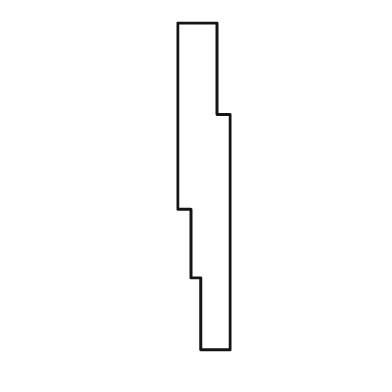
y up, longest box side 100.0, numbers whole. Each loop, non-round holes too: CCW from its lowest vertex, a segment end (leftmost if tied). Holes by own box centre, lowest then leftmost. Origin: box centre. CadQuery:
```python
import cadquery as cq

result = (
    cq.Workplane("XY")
    .moveTo(-1.0, -50.0)
    .lineTo(8.0, -50.0)
    .lineTo(8.0, 22.0)
    .lineTo(4.0, 22.0)
    .lineTo(4.0, 50.0)
    .lineTo(-8.0, 50.0)
    .lineTo(-8.0, -7.0)
    .lineTo(-4.0, -7.0)
    .lineTo(-4.0, -28.0)
    .lineTo(-1.0, -28.0)
    .close()
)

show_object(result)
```